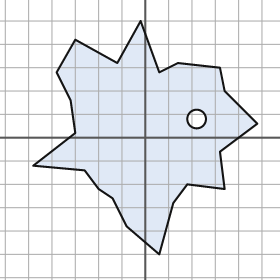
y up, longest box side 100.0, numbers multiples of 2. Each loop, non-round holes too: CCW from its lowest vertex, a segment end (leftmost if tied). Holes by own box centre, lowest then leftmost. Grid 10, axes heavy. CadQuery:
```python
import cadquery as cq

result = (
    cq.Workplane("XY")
    .moveTo(6.0, -50.0)
    .lineTo(12.0, -28.0)
    .lineTo(18.0, -20.0)
    .lineTo(34.0, -22.0)
    .lineTo(32.0, -6.0)
    .lineTo(48.0, 6.0)
    .lineTo(34.0, 20.0)
    .lineTo(32.0, 30.0)
    .lineTo(14.0, 32.0)
    .lineTo(6.0, 28.0)
    .lineTo(-2.0, 50.0)
    .lineTo(-12.0, 32.0)
    .lineTo(-30.0, 42.0)
    .lineTo(-38.0, 28.0)
    .lineTo(-32.0, 16.0)
    .lineTo(-30.0, 2.0)
    .lineTo(-48.0, -12.0)
    .lineTo(-26.0, -14.0)
    .lineTo(-20.0, -22.0)
    .lineTo(-14.0, -26.0)
    .lineTo(-8.0, -38.0)
    .close()
    .moveTo(22.0, 8.0)
    .circle(4.0)
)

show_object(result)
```